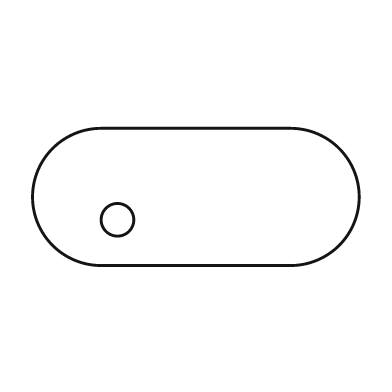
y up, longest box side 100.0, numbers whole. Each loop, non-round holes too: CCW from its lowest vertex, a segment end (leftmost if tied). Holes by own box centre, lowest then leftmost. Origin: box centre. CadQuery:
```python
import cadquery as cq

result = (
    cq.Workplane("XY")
    .moveTo(-29.0, -21.0)
    .lineTo(29.0, -21.0)
    .threePointArc((50.0, 0.0), (29.0, 21.0))
    .lineTo(-29.0, 21.0)
    .threePointArc((-50.0, 0.0), (-29.0, -21.0))
    .close()
    .moveTo(-24.0, -7.0)
    .circle(5.0)
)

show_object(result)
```